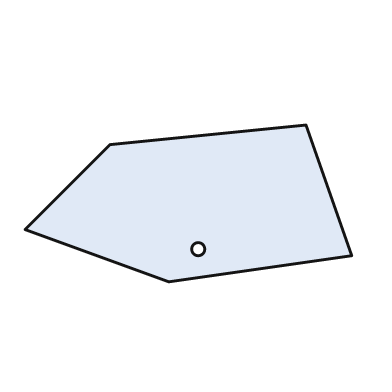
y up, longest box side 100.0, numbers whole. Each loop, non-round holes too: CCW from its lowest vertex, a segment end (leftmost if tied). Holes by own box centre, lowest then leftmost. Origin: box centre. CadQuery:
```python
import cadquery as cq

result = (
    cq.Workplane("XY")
    .moveTo(-6.0, -24.0)
    .lineTo(50.0, -16.0)
    .lineTo(36.0, 24.0)
    .lineTo(-24.0, 18.0)
    .lineTo(-50.0, -8.0)
    .close()
    .moveTo(3.0, -14.0)
    .circle(2.0)
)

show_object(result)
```